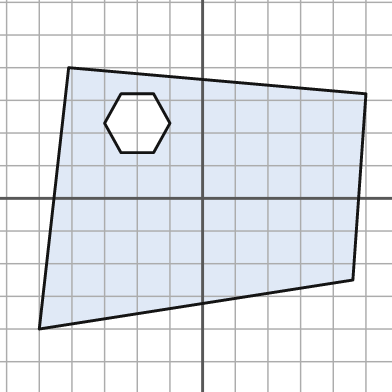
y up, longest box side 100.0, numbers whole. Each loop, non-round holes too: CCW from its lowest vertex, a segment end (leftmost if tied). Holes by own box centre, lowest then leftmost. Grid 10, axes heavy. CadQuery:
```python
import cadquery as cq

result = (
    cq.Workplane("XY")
    .moveTo(-50.0, -40.0)
    .lineTo(46.0, -25.0)
    .lineTo(50.0, 32.0)
    .lineTo(-41.0, 40.0)
    .close()
    .moveTo(-25.0, 14.0)
    .lineTo(-15.0, 14.0)
    .lineTo(-10.0, 23.0)
    .lineTo(-15.0, 32.0)
    .lineTo(-25.0, 32.0)
    .lineTo(-30.0, 23.0)
    .close()
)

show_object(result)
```